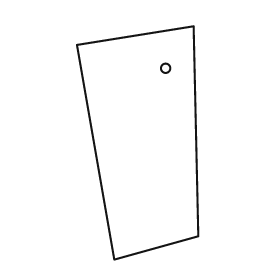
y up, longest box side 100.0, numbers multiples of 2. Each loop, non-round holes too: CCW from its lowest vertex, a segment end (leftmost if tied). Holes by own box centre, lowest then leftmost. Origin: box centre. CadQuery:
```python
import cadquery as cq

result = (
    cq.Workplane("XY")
    .moveTo(-10.0, -50.0)
    .lineTo(26.0, -40.0)
    .lineTo(24.0, 50.0)
    .lineTo(-26.0, 42.0)
    .close()
    .moveTo(12.0, 32.0)
    .circle(2.0)
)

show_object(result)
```